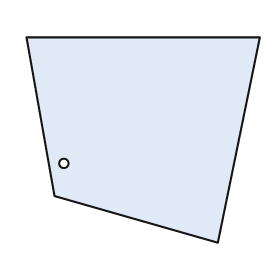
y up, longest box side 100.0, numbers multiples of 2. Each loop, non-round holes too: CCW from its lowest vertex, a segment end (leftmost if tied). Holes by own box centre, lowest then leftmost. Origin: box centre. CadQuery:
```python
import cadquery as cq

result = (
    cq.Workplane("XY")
    .moveTo(32.0, -44.0)
    .lineTo(50.0, 44.0)
    .lineTo(-50.0, 44.0)
    .lineTo(-38.0, -24.0)
    .close()
    .moveTo(-34.0, -10.0)
    .circle(2.0)
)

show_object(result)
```